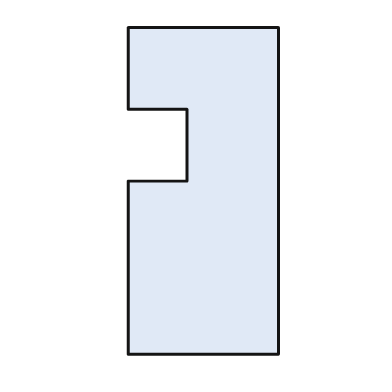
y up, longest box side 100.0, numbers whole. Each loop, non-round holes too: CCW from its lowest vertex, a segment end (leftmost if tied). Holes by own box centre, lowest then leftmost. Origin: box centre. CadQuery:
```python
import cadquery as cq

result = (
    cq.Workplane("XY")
    .moveTo(-23.0, -50.0)
    .lineTo(23.0, -50.0)
    .lineTo(23.0, 50.0)
    .lineTo(-23.0, 50.0)
    .lineTo(-23.0, 25.0)
    .lineTo(-5.0, 25.0)
    .lineTo(-5.0, 3.0)
    .lineTo(-23.0, 3.0)
    .close()
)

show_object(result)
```